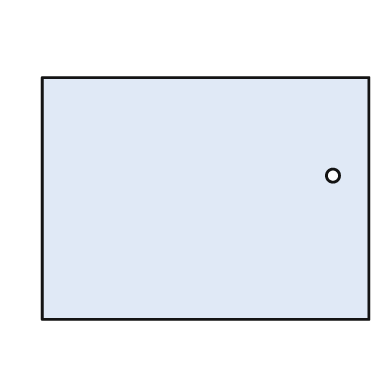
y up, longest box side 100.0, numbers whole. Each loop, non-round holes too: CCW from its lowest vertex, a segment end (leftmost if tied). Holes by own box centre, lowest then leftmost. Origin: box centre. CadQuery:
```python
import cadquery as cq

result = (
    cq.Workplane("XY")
    .moveTo(-50.0, -37.0)
    .lineTo(50.0, -37.0)
    .lineTo(50.0, 37.0)
    .lineTo(-50.0, 37.0)
    .close()
    .moveTo(39.0, 7.0)
    .circle(2.0)
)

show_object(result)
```